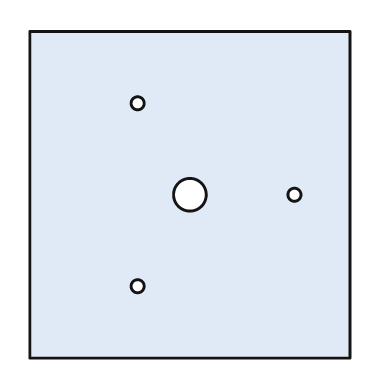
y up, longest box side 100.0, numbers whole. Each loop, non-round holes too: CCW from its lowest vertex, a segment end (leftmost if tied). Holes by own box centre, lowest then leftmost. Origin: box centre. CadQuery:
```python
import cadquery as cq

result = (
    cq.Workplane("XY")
    .moveTo(-49.0, -50.0)
    .lineTo(49.0, -50.0)
    .lineTo(49.0, 50.0)
    .lineTo(-49.0, 50.0)
    .close()
    .moveTo(-16.0, -28.0)
    .circle(2.0)
    .moveTo(0.0, 0.0)
    .circle(5.0)
    .moveTo(32.0, 0.0)
    .circle(2.0)
    .moveTo(-16.0, 28.0)
    .circle(2.0)
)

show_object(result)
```